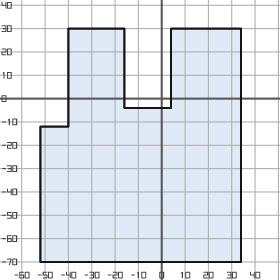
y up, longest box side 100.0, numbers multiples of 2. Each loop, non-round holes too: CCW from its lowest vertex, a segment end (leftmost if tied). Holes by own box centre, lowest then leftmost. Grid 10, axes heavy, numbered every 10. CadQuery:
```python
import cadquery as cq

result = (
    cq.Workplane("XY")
    .moveTo(-52.0, -70.0)
    .lineTo(34.0, -70.0)
    .lineTo(34.0, 30.0)
    .lineTo(4.0, 30.0)
    .lineTo(4.0, -4.0)
    .lineTo(-16.0, -4.0)
    .lineTo(-16.0, 30.0)
    .lineTo(-40.0, 30.0)
    .lineTo(-40.0, -12.0)
    .lineTo(-52.0, -12.0)
    .close()
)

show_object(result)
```